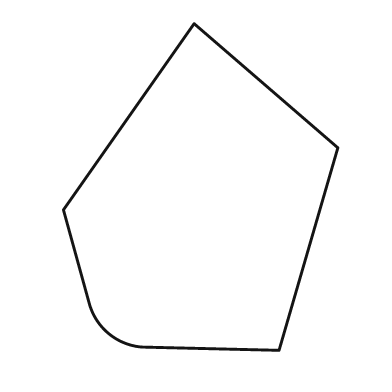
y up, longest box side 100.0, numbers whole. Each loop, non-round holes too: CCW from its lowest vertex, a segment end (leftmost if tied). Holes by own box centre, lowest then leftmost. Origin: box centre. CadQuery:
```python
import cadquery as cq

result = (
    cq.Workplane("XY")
    .moveTo(24.0, -50.0)
    .lineTo(42.0, 12.0)
    .lineTo(-2.0, 50.0)
    .lineTo(-42.0, -7.0)
    .lineTo(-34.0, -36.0)
    .threePointArc((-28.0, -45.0), (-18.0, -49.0))
    .close()
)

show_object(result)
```